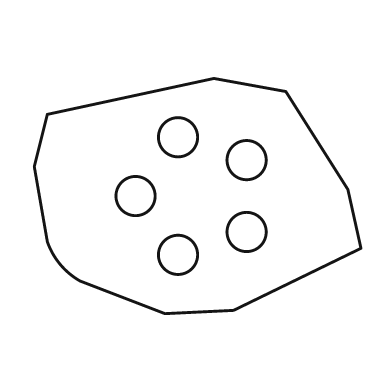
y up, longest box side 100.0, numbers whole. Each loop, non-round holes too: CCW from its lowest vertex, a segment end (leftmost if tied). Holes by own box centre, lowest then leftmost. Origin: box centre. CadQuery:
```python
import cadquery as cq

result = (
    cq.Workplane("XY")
    .moveTo(-10.0, -36.0)
    .lineTo(11.0, -35.0)
    .lineTo(50.0, -16.0)
    .lineTo(46.0, 2.0)
    .lineTo(27.0, 32.0)
    .lineTo(5.0, 36.0)
    .lineTo(-46.0, 25.0)
    .lineTo(-50.0, 9.0)
    .lineTo(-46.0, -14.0)
    .threePointArc((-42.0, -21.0), (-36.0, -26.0))
    .close()
    .moveTo(-6.0, -18.0)
    .circle(6.0)
    .moveTo(15.0, -11.0)
    .circle(6.0)
    .moveTo(-19.0, 0.0)
    .circle(6.0)
    .moveTo(15.0, 11.0)
    .circle(6.0)
    .moveTo(-6.0, 18.0)
    .circle(6.0)
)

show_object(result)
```